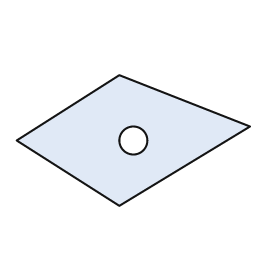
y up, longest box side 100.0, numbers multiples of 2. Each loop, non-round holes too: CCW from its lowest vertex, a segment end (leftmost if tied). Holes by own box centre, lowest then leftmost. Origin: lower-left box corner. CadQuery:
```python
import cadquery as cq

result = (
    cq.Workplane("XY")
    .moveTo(44.0, 0.0)
    .lineTo(100.0, 34.0)
    .lineTo(44.0, 56.0)
    .lineTo(0.0, 28.0)
    .close()
    .moveTo(50.0, 28.0)
    .circle(6.0)
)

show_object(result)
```